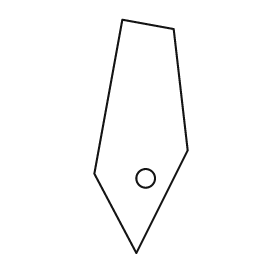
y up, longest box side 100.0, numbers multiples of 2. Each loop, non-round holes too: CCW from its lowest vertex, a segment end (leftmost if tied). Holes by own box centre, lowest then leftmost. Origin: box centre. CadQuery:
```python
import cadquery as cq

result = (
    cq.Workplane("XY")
    .moveTo(-2.0, -50.0)
    .lineTo(20.0, -6.0)
    .lineTo(14.0, 46.0)
    .lineTo(-8.0, 50.0)
    .lineTo(-20.0, -16.0)
    .close()
    .moveTo(2.0, -18.0)
    .circle(4.0)
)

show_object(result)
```